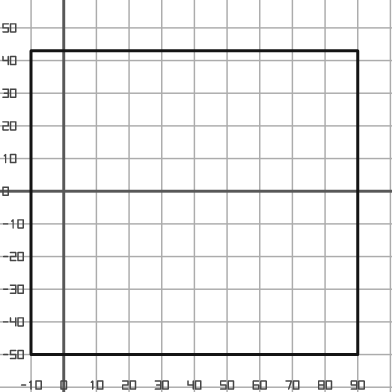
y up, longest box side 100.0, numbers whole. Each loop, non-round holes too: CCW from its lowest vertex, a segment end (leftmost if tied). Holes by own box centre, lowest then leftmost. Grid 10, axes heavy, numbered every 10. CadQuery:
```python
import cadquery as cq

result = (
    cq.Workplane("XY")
    .moveTo(-10.0, -50.0)
    .lineTo(90.0, -50.0)
    .lineTo(90.0, 43.0)
    .lineTo(-10.0, 43.0)
    .close()
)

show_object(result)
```